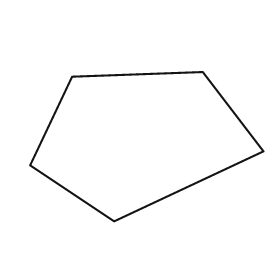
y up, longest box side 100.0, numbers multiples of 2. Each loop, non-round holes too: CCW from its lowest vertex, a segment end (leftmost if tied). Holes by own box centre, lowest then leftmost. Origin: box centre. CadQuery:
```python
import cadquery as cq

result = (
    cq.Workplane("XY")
    .moveTo(-14.0, -32.0)
    .lineTo(50.0, -2.0)
    .lineTo(24.0, 32.0)
    .lineTo(-32.0, 30.0)
    .lineTo(-50.0, -8.0)
    .close()
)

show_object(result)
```